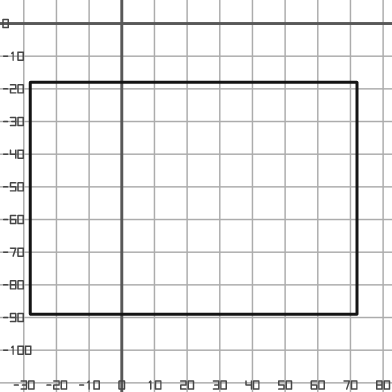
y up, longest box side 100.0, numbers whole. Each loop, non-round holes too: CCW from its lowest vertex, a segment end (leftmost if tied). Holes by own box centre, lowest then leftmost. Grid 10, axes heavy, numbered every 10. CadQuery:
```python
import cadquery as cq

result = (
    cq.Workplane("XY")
    .moveTo(-28.0, -89.0)
    .lineTo(72.0, -89.0)
    .lineTo(72.0, -18.0)
    .lineTo(-28.0, -18.0)
    .close()
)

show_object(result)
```